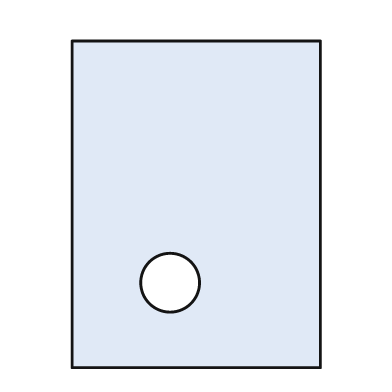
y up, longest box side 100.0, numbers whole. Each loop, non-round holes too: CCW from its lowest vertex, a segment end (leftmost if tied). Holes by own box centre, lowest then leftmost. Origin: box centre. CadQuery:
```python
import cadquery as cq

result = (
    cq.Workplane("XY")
    .moveTo(-38.0, -50.0)
    .lineTo(38.0, -50.0)
    .lineTo(38.0, 50.0)
    .lineTo(-38.0, 50.0)
    .close()
    .moveTo(-8.0, -24.0)
    .circle(9.0)
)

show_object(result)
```